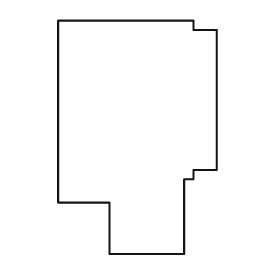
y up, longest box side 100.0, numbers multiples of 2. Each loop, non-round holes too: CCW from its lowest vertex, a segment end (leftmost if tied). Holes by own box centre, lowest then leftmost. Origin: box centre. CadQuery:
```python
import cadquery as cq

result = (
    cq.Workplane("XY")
    .moveTo(-12.0, -50.0)
    .lineTo(20.0, -50.0)
    .lineTo(20.0, -18.0)
    .lineTo(24.0, -18.0)
    .lineTo(24.0, -14.0)
    .lineTo(34.0, -14.0)
    .lineTo(34.0, 46.0)
    .lineTo(24.0, 46.0)
    .lineTo(24.0, 50.0)
    .lineTo(-34.0, 50.0)
    .lineTo(-34.0, -28.0)
    .lineTo(-12.0, -28.0)
    .close()
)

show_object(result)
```